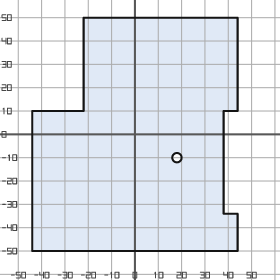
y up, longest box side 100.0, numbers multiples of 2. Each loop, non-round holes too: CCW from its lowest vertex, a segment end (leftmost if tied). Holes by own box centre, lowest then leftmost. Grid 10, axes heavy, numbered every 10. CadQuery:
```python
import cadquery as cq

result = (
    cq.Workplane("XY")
    .moveTo(-44.0, -50.0)
    .lineTo(44.0, -50.0)
    .lineTo(44.0, -34.0)
    .lineTo(38.0, -34.0)
    .lineTo(38.0, 10.0)
    .lineTo(44.0, 10.0)
    .lineTo(44.0, 50.0)
    .lineTo(-22.0, 50.0)
    .lineTo(-22.0, 10.0)
    .lineTo(-44.0, 10.0)
    .close()
    .moveTo(18.0, -10.0)
    .circle(2.0)
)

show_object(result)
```